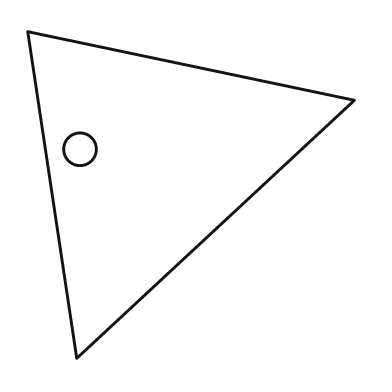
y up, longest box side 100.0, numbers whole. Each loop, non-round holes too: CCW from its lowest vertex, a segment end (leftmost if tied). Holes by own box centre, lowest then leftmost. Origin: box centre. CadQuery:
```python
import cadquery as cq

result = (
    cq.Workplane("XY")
    .moveTo(-35.0, -50.0)
    .lineTo(50.0, 29.0)
    .lineTo(-50.0, 50.0)
    .close()
    .moveTo(-34.0, 14.0)
    .circle(5.0)
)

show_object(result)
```